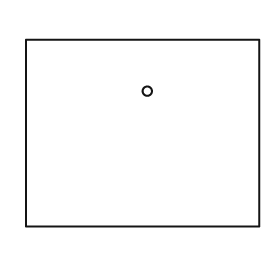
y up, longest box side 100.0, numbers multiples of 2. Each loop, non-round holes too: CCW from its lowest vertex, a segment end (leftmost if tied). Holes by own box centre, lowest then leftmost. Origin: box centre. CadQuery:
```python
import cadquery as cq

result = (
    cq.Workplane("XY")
    .moveTo(-50.0, -40.0)
    .lineTo(50.0, -40.0)
    .lineTo(50.0, 40.0)
    .lineTo(-50.0, 40.0)
    .close()
    .moveTo(2.0, 18.0)
    .circle(2.0)
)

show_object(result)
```